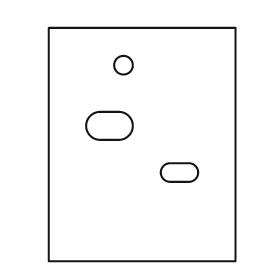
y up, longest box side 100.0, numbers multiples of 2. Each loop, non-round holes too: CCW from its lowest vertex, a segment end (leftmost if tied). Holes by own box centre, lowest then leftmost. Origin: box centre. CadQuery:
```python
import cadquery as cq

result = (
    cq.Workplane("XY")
    .moveTo(-40.0, -50.0)
    .lineTo(40.0, -50.0)
    .lineTo(40.0, 50.0)
    .lineTo(-40.0, 50.0)
    .close()
    .moveTo(12.0, -16.0)
    .lineTo(20.0, -16.0)
    .threePointArc((24.0, -12.0), (20.0, -8.0))
    .lineTo(12.0, -8.0)
    .threePointArc((8.0, -12.0), (12.0, -16.0))
    .close()
    .moveTo(-18.0, 2.0)
    .lineTo(-10.0, 2.0)
    .threePointArc((-4.0, 8.0), (-10.0, 14.0))
    .lineTo(-18.0, 14.0)
    .threePointArc((-24.0, 8.0), (-18.0, 2.0))
    .close()
    .moveTo(-8.0, 34.0)
    .circle(4.0)
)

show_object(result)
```